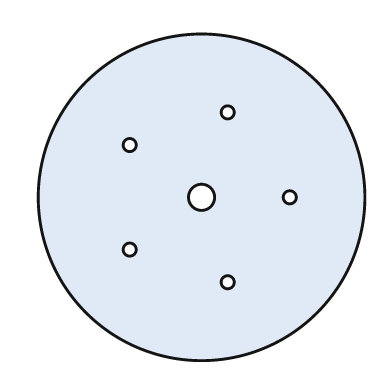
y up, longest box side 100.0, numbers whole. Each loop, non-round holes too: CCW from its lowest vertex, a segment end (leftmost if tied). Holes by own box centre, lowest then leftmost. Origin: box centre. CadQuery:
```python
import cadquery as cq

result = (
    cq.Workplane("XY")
    .moveTo(0.0, 0.0)
    .circle(50.0)
    .moveTo(8.0, -26.0)
    .circle(2.0)
    .moveTo(-22.0, -16.0)
    .circle(2.0)
    .moveTo(0.0, 0.0)
    .circle(4.0)
    .moveTo(27.0, 0.0)
    .circle(2.0)
    .moveTo(-22.0, 16.0)
    .circle(2.0)
    .moveTo(8.0, 26.0)
    .circle(2.0)
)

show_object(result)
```